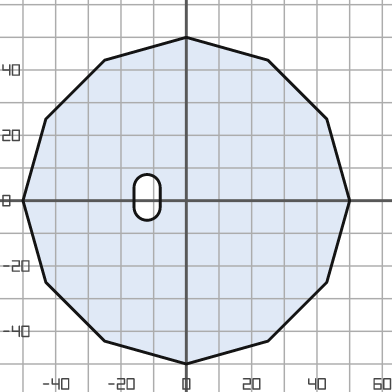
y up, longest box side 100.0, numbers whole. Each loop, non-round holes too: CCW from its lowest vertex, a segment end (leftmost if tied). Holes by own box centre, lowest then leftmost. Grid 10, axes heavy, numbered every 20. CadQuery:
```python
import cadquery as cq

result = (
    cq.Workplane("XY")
    .moveTo(0.0, -50.0)
    .lineTo(25.0, -43.0)
    .lineTo(43.0, -25.0)
    .lineTo(50.0, 0.0)
    .lineTo(43.0, 25.0)
    .lineTo(25.0, 43.0)
    .lineTo(0.0, 50.0)
    .lineTo(-25.0, 43.0)
    .lineTo(-43.0, 25.0)
    .lineTo(-50.0, 0.0)
    .lineTo(-43.0, -25.0)
    .lineTo(-25.0, -43.0)
    .close()
    .moveTo(-16.0, -2.0)
    .threePointArc((-12.0, -6.0), (-8.0, -2.0))
    .lineTo(-8.0, 4.0)
    .threePointArc((-12.0, 8.0), (-16.0, 4.0))
    .close()
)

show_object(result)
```